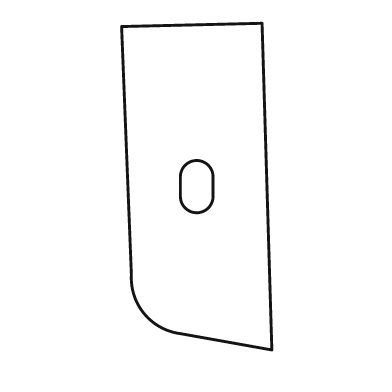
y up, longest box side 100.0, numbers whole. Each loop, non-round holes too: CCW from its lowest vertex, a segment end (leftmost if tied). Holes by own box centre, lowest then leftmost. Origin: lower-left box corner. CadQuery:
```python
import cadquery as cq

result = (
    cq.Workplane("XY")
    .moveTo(46.0, 0.0)
    .lineTo(43.0, 100.0)
    .lineTo(0.0, 99.0)
    .lineTo(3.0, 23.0)
    .threePointArc((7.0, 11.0), (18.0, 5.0))
    .close()
    .moveTo(18.0, 47.0)
    .threePointArc((23.0, 42.0), (28.0, 47.0))
    .lineTo(28.0, 53.0)
    .threePointArc((23.0, 58.0), (18.0, 53.0))
    .close()
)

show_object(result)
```